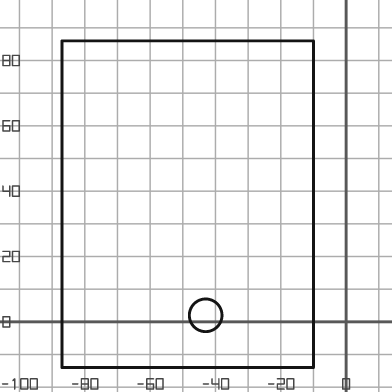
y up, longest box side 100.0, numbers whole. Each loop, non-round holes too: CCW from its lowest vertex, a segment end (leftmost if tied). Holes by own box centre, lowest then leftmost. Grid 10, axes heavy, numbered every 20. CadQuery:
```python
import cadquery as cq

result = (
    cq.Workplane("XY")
    .moveTo(-87.0, -14.0)
    .lineTo(-10.0, -14.0)
    .lineTo(-10.0, 86.0)
    .lineTo(-87.0, 86.0)
    .close()
    .moveTo(-43.0, 2.0)
    .circle(5.0)
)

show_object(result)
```